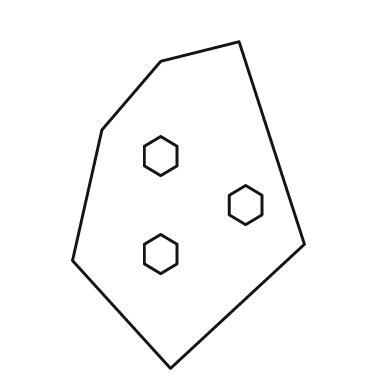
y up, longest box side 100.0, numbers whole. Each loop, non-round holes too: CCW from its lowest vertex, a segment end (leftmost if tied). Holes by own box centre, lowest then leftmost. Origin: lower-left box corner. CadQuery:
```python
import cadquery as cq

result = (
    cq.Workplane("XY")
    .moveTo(30.0, 0.0)
    .lineTo(71.0, 38.0)
    .lineTo(51.0, 100.0)
    .lineTo(27.0, 94.0)
    .lineTo(9.0, 73.0)
    .lineTo(0.0, 33.0)
    .close()
    .moveTo(27.0, 29.0)
    .lineTo(32.0, 32.0)
    .lineTo(32.0, 38.0)
    .lineTo(27.0, 41.0)
    .lineTo(22.0, 38.0)
    .lineTo(22.0, 32.0)
    .close()
    .moveTo(53.0, 44.0)
    .lineTo(58.0, 47.0)
    .lineTo(58.0, 53.0)
    .lineTo(53.0, 56.0)
    .lineTo(48.0, 53.0)
    .lineTo(48.0, 47.0)
    .close()
    .moveTo(27.0, 59.0)
    .lineTo(32.0, 62.0)
    .lineTo(32.0, 68.0)
    .lineTo(27.0, 71.0)
    .lineTo(22.0, 68.0)
    .lineTo(22.0, 62.0)
    .close()
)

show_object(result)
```